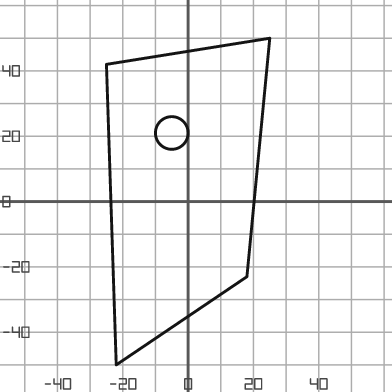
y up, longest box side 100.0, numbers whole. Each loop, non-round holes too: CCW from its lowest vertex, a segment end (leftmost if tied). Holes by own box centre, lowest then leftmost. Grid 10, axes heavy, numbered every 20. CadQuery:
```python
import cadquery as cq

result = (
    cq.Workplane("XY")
    .moveTo(-22.0, -50.0)
    .lineTo(18.0, -23.0)
    .lineTo(25.0, 50.0)
    .lineTo(-25.0, 42.0)
    .close()
    .moveTo(-5.0, 21.0)
    .circle(5.0)
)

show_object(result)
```